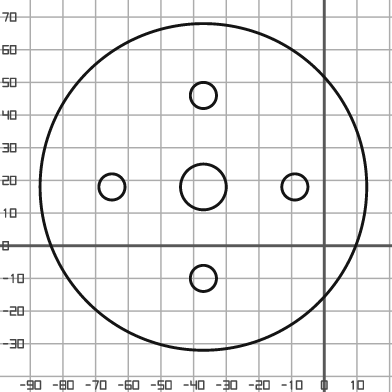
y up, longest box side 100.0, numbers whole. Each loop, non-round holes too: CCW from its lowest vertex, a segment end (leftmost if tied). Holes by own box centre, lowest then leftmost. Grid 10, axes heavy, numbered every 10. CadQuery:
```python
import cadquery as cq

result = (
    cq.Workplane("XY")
    .moveTo(-37.0, 18.0)
    .circle(50.0)
    .moveTo(-37.0, -10.0)
    .circle(4.0)
    .moveTo(-65.0, 18.0)
    .circle(4.0)
    .moveTo(-37.0, 18.0)
    .circle(7.0)
    .moveTo(-9.0, 18.0)
    .circle(4.0)
    .moveTo(-37.0, 46.0)
    .circle(4.0)
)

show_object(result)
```